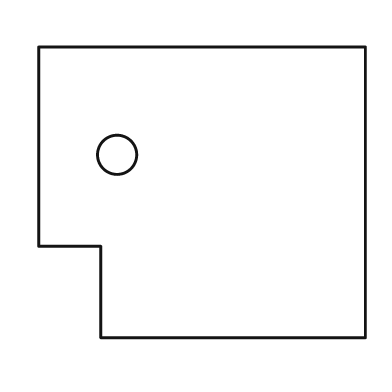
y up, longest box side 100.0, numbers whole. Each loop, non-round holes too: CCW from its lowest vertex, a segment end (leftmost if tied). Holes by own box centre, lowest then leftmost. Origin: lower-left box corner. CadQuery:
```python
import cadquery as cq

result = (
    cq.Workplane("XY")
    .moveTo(19.0, 0.0)
    .lineTo(100.0, 0.0)
    .lineTo(100.0, 89.0)
    .lineTo(0.0, 89.0)
    .lineTo(0.0, 28.0)
    .lineTo(19.0, 28.0)
    .close()
    .moveTo(24.0, 56.0)
    .circle(6.0)
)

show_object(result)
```